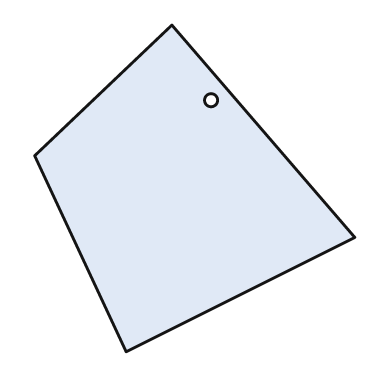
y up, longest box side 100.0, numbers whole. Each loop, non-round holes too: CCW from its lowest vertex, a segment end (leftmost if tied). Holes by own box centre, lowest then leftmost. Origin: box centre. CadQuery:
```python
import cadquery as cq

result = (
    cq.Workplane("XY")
    .moveTo(-21.0, -50.0)
    .lineTo(49.0, -15.0)
    .lineTo(-7.0, 50.0)
    .lineTo(-49.0, 10.0)
    .close()
    .moveTo(5.0, 27.0)
    .circle(2.0)
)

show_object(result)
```